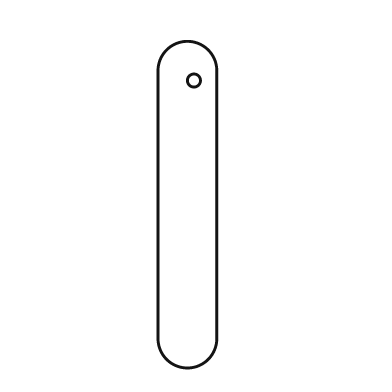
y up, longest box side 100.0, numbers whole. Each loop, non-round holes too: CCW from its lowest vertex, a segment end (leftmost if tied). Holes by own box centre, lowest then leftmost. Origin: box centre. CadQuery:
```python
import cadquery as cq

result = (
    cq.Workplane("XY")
    .moveTo(-9.0, -41.0)
    .threePointArc((0.0, -50.0), (9.0, -41.0))
    .lineTo(9.0, 41.0)
    .threePointArc((0.0, 50.0), (-9.0, 41.0))
    .close()
    .moveTo(2.0, 38.0)
    .circle(2.0)
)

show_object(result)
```